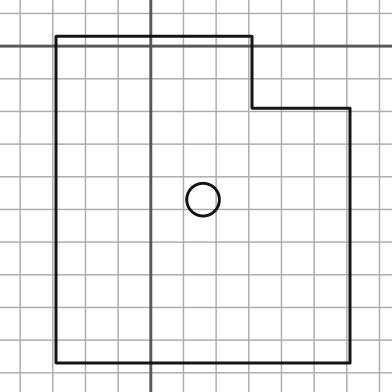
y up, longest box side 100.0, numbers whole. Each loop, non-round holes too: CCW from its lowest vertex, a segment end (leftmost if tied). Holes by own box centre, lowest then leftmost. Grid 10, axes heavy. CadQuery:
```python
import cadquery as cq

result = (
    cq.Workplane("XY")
    .moveTo(-29.0, -97.0)
    .lineTo(61.0, -97.0)
    .lineTo(61.0, -19.0)
    .lineTo(31.0, -19.0)
    .lineTo(31.0, 3.0)
    .lineTo(-29.0, 3.0)
    .close()
    .moveTo(16.0, -47.0)
    .circle(5.0)
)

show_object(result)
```